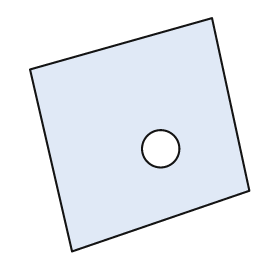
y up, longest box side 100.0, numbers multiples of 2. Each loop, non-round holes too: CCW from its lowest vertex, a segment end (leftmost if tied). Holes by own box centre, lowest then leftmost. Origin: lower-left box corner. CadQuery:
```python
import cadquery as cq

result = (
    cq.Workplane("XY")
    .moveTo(18.0, 0.0)
    .lineTo(94.0, 26.0)
    .lineTo(78.0, 100.0)
    .lineTo(0.0, 78.0)
    .close()
    .moveTo(56.0, 44.0)
    .circle(8.0)
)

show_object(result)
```